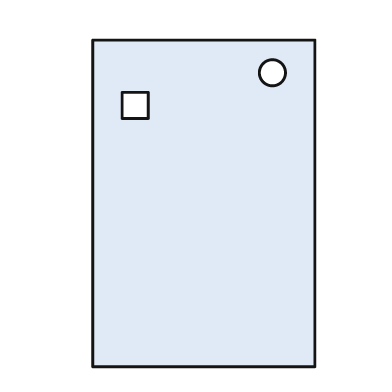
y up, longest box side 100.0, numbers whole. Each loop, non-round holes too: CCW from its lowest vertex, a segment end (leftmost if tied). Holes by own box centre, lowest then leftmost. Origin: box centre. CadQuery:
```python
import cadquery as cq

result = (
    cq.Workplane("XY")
    .moveTo(-34.0, -50.0)
    .lineTo(34.0, -50.0)
    .lineTo(34.0, 50.0)
    .lineTo(-34.0, 50.0)
    .close()
    .moveTo(-25.0, 26.0)
    .lineTo(-17.0, 26.0)
    .lineTo(-17.0, 34.0)
    .lineTo(-25.0, 34.0)
    .close()
    .moveTo(21.0, 40.0)
    .circle(4.0)
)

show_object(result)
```